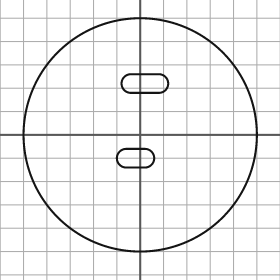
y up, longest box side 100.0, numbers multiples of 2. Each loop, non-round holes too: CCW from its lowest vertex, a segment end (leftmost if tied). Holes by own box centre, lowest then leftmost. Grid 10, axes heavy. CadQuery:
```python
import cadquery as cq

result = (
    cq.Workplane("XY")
    .moveTo(0.0, 0.0)
    .circle(50.0)
    .moveTo(-6.0, -14.0)
    .lineTo(2.0, -14.0)
    .threePointArc((6.0, -10.0), (2.0, -6.0))
    .lineTo(-6.0, -6.0)
    .threePointArc((-10.0, -10.0), (-6.0, -14.0))
    .close()
    .moveTo(-4.0, 18.0)
    .lineTo(8.0, 18.0)
    .threePointArc((12.0, 22.0), (8.0, 26.0))
    .lineTo(-4.0, 26.0)
    .threePointArc((-8.0, 22.0), (-4.0, 18.0))
    .close()
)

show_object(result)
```